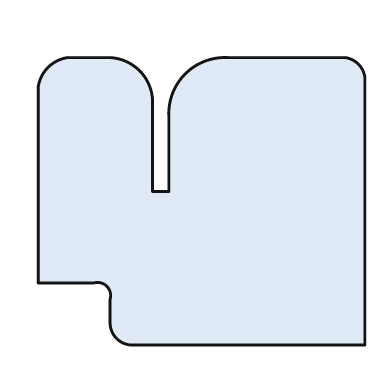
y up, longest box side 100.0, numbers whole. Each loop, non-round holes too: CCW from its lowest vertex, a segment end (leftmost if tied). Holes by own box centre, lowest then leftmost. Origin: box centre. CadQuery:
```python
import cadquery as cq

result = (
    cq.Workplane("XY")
    .moveTo(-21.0, -44.0)
    .lineTo(50.0, -44.0)
    .lineTo(50.0, 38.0)
    .threePointArc((48.0, 42.0), (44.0, 44.0))
    .lineTo(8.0, 44.0)
    .threePointArc((-5.0, 39.0), (-10.0, 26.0))
    .lineTo(-10.0, 3.0)
    .lineTo(-15.0, 3.0)
    .lineTo(-15.0, 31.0)
    .threePointArc((-19.0, 40.0), (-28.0, 44.0))
    .lineTo(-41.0, 44.0)
    .threePointArc((-47.0, 41.0), (-50.0, 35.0))
    .lineTo(-50.0, -25.0)
    .lineTo(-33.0, -25.0)
    .threePointArc((-29.0, -26.0), (-28.0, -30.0))
    .lineTo(-28.0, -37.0)
    .threePointArc((-26.0, -42.0), (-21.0, -44.0))
    .close()
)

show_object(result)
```